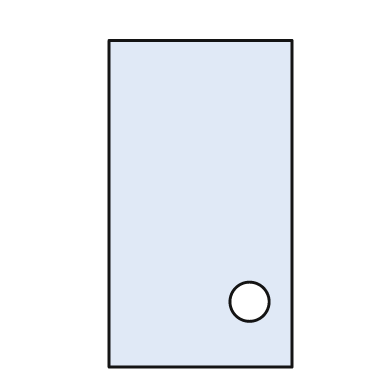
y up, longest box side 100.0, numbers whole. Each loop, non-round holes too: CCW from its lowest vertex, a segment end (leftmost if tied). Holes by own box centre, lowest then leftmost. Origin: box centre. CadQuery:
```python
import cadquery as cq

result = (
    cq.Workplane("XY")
    .moveTo(-28.0, -50.0)
    .lineTo(28.0, -50.0)
    .lineTo(28.0, 50.0)
    .lineTo(-28.0, 50.0)
    .close()
    .moveTo(15.0, -30.0)
    .circle(6.0)
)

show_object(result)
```